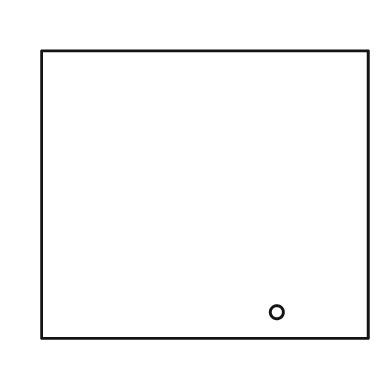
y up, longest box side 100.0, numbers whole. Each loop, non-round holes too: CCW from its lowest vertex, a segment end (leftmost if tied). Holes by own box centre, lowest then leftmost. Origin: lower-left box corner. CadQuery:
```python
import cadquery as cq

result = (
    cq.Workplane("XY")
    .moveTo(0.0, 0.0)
    .lineTo(100.0, 0.0)
    .lineTo(100.0, 88.0)
    .lineTo(0.0, 88.0)
    .close()
    .moveTo(72.0, 8.0)
    .circle(2.0)
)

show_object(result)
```